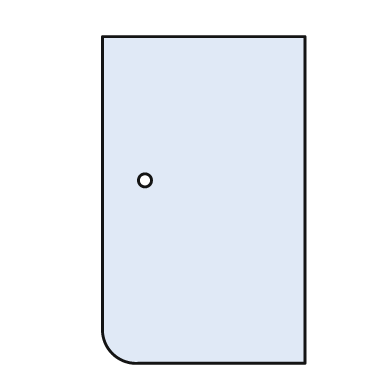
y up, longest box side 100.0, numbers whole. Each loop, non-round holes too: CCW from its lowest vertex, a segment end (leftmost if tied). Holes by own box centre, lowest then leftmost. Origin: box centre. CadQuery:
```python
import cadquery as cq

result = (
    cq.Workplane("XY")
    .moveTo(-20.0, -50.0)
    .lineTo(31.0, -50.0)
    .lineTo(31.0, 50.0)
    .lineTo(-31.0, 50.0)
    .lineTo(-31.0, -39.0)
    .threePointArc((-28.0, -47.0), (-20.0, -50.0))
    .close()
    .moveTo(-18.0, 6.0)
    .circle(2.0)
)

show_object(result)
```